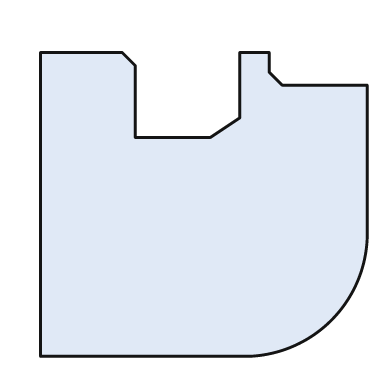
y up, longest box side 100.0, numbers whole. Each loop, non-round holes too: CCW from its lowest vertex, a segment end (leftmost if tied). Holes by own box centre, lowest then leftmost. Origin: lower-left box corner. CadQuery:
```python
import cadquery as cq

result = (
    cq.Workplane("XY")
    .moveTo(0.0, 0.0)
    .lineTo(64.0, 0.0)
    .threePointArc((89.0, 11.0), (100.0, 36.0))
    .lineTo(100.0, 83.0)
    .lineTo(74.0, 83.0)
    .lineTo(70.0, 87.0)
    .lineTo(70.0, 93.0)
    .lineTo(61.0, 93.0)
    .lineTo(61.0, 73.0)
    .lineTo(52.0, 67.0)
    .lineTo(29.0, 67.0)
    .lineTo(29.0, 89.0)
    .lineTo(25.0, 93.0)
    .lineTo(0.0, 93.0)
    .close()
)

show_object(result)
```